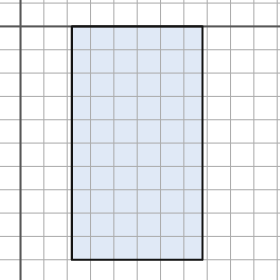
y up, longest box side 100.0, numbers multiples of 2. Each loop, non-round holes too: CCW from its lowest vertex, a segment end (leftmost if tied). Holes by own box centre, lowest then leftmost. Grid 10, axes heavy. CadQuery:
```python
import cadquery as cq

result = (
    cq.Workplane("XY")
    .moveTo(22.0, -100.0)
    .lineTo(78.0, -100.0)
    .lineTo(78.0, 0.0)
    .lineTo(22.0, 0.0)
    .close()
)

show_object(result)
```